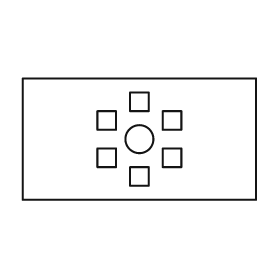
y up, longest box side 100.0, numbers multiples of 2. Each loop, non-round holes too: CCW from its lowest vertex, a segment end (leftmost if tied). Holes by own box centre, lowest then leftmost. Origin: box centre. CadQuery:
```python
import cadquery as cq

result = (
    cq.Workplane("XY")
    .moveTo(-50.0, -26.0)
    .lineTo(50.0, -26.0)
    .lineTo(50.0, 26.0)
    .lineTo(-50.0, 26.0)
    .close()
    .moveTo(-4.0, -20.0)
    .lineTo(4.0, -20.0)
    .lineTo(4.0, -12.0)
    .lineTo(-4.0, -12.0)
    .close()
    .moveTo(-18.0, -12.0)
    .lineTo(-10.0, -12.0)
    .lineTo(-10.0, -4.0)
    .lineTo(-18.0, -4.0)
    .close()
    .moveTo(10.0, -12.0)
    .lineTo(18.0, -12.0)
    .lineTo(18.0, -4.0)
    .lineTo(10.0, -4.0)
    .close()
    .moveTo(0.0, 0.0)
    .circle(6.0)
    .moveTo(-18.0, 4.0)
    .lineTo(-10.0, 4.0)
    .lineTo(-10.0, 12.0)
    .lineTo(-18.0, 12.0)
    .close()
    .moveTo(10.0, 4.0)
    .lineTo(18.0, 4.0)
    .lineTo(18.0, 12.0)
    .lineTo(10.0, 12.0)
    .close()
    .moveTo(-4.0, 12.0)
    .lineTo(4.0, 12.0)
    .lineTo(4.0, 20.0)
    .lineTo(-4.0, 20.0)
    .close()
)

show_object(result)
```